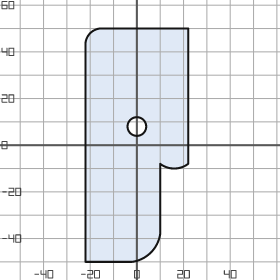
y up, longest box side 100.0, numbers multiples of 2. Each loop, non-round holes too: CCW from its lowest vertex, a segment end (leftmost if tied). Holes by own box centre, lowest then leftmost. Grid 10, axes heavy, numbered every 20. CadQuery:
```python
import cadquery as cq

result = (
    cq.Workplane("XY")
    .moveTo(-22.0, -50.0)
    .lineTo(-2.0, -50.0)
    .threePointArc((6.0, -46.0), (10.0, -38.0))
    .lineTo(10.0, -8.0)
    .threePointArc((16.0, -10.0), (22.0, -8.0))
    .lineTo(22.0, 50.0)
    .lineTo(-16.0, 50.0)
    .threePointArc((-20.0, 48.0), (-22.0, 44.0))
    .close()
    .moveTo(0.0, 8.0)
    .circle(4.0)
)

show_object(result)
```